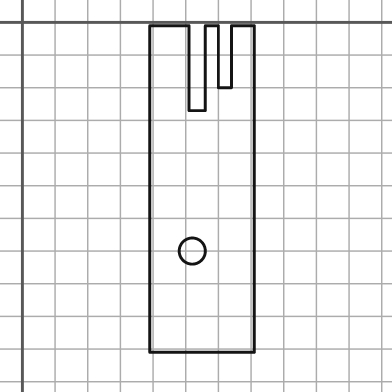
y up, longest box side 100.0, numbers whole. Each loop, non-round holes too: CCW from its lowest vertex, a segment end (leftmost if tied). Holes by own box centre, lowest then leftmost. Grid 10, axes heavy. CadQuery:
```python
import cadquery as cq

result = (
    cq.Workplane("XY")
    .moveTo(39.0, -101.0)
    .lineTo(71.0, -101.0)
    .lineTo(71.0, -1.0)
    .lineTo(64.0, -1.0)
    .lineTo(64.0, -20.0)
    .lineTo(60.0, -20.0)
    .lineTo(60.0, -1.0)
    .lineTo(56.0, -1.0)
    .lineTo(56.0, -27.0)
    .lineTo(51.0, -27.0)
    .lineTo(51.0, -1.0)
    .lineTo(39.0, -1.0)
    .close()
    .moveTo(52.0, -70.0)
    .circle(4.0)
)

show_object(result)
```